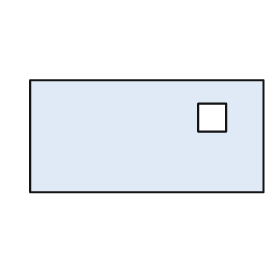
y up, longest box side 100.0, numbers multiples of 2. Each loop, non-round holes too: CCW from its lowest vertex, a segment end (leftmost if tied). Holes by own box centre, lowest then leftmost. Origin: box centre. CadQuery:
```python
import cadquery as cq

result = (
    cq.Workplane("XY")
    .moveTo(-50.0, -24.0)
    .lineTo(50.0, -24.0)
    .lineTo(50.0, 24.0)
    .lineTo(-50.0, 24.0)
    .close()
    .moveTo(22.0, 2.0)
    .lineTo(34.0, 2.0)
    .lineTo(34.0, 14.0)
    .lineTo(22.0, 14.0)
    .close()
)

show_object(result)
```